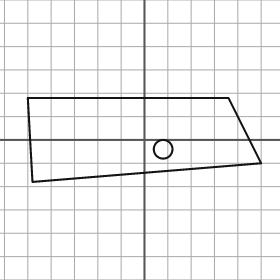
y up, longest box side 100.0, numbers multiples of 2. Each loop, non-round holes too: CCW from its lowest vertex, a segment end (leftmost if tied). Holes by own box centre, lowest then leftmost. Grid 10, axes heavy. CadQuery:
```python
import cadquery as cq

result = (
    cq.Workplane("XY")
    .moveTo(-48.0, -18.0)
    .lineTo(50.0, -10.0)
    .lineTo(36.0, 18.0)
    .lineTo(-50.0, 18.0)
    .close()
    .moveTo(8.0, -4.0)
    .circle(4.0)
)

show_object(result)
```